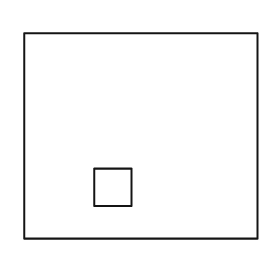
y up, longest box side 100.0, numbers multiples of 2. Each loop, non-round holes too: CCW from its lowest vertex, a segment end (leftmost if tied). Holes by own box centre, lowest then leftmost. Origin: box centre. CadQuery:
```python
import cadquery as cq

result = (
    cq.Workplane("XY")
    .moveTo(-50.0, -44.0)
    .lineTo(50.0, -44.0)
    .lineTo(50.0, 44.0)
    .lineTo(-50.0, 44.0)
    .close()
    .moveTo(-20.0, -30.0)
    .lineTo(-4.0, -30.0)
    .lineTo(-4.0, -14.0)
    .lineTo(-20.0, -14.0)
    .close()
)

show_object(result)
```